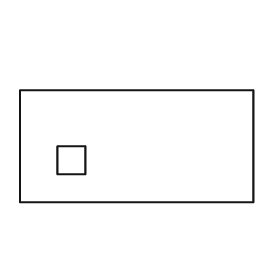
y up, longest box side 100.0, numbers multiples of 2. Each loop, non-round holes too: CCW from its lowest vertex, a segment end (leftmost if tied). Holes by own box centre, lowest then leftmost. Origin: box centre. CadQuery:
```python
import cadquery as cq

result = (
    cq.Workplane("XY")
    .moveTo(-50.0, -24.0)
    .lineTo(50.0, -24.0)
    .lineTo(50.0, 24.0)
    .lineTo(-50.0, 24.0)
    .close()
    .moveTo(-34.0, -12.0)
    .lineTo(-22.0, -12.0)
    .lineTo(-22.0, 0.0)
    .lineTo(-34.0, 0.0)
    .close()
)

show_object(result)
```